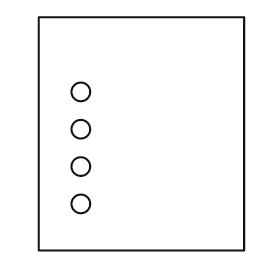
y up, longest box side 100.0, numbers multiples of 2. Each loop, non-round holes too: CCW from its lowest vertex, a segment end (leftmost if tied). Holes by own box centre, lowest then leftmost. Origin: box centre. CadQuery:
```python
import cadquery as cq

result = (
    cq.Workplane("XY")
    .moveTo(-44.0, -50.0)
    .lineTo(44.0, -50.0)
    .lineTo(44.0, 50.0)
    .lineTo(-44.0, 50.0)
    .close()
    .moveTo(-26.0, -30.0)
    .circle(4.0)
    .moveTo(-26.0, -14.0)
    .circle(4.0)
    .moveTo(-26.0, 2.0)
    .circle(4.0)
    .moveTo(-26.0, 18.0)
    .circle(4.0)
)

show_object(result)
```